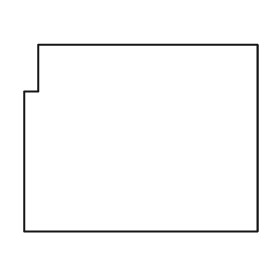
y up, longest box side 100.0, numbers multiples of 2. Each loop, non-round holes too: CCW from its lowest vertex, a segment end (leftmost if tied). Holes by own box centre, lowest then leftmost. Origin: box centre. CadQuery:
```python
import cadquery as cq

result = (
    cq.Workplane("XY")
    .moveTo(-50.0, -40.0)
    .lineTo(50.0, -40.0)
    .lineTo(50.0, 40.0)
    .lineTo(-44.0, 40.0)
    .lineTo(-44.0, 20.0)
    .lineTo(-50.0, 20.0)
    .close()
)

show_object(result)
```